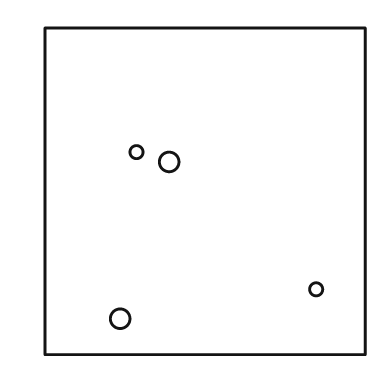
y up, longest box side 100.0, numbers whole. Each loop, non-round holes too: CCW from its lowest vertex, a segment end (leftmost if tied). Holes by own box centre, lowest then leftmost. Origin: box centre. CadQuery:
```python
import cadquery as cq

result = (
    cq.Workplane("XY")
    .moveTo(-49.0, -50.0)
    .lineTo(49.0, -50.0)
    .lineTo(49.0, 50.0)
    .lineTo(-49.0, 50.0)
    .close()
    .moveTo(-26.0, -39.0)
    .circle(3.0)
    .moveTo(34.0, -30.0)
    .circle(2.0)
    .moveTo(-11.0, 9.0)
    .circle(3.0)
    .moveTo(-21.0, 12.0)
    .circle(2.0)
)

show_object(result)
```